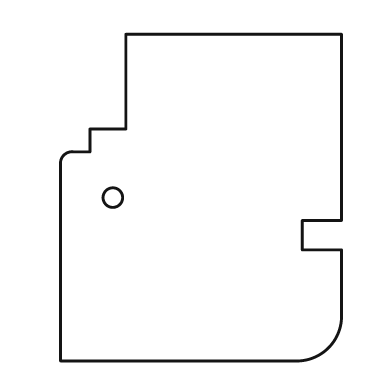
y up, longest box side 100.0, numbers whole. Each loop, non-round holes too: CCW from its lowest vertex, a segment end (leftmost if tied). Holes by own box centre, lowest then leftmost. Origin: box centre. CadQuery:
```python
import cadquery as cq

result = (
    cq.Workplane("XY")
    .moveTo(-43.0, -50.0)
    .lineTo(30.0, -50.0)
    .threePointArc((39.0, -46.0), (43.0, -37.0))
    .lineTo(43.0, -16.0)
    .lineTo(31.0, -16.0)
    .lineTo(31.0, -7.0)
    .lineTo(43.0, -7.0)
    .lineTo(43.0, 50.0)
    .lineTo(-23.0, 50.0)
    .lineTo(-23.0, 21.0)
    .lineTo(-34.0, 21.0)
    .lineTo(-34.0, 14.0)
    .lineTo(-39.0, 14.0)
    .threePointArc((-42.0, 13.0), (-43.0, 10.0))
    .close()
    .moveTo(-27.0, 0.0)
    .circle(3.0)
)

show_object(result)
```